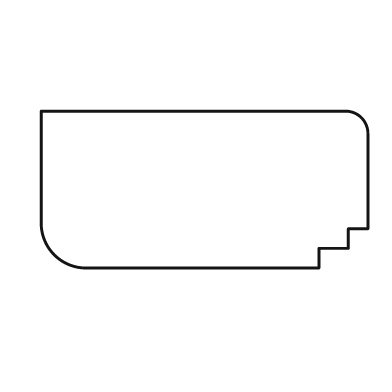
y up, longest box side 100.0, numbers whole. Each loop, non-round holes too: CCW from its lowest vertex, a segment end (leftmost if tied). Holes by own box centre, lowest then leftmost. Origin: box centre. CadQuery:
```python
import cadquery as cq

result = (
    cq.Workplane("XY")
    .moveTo(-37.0, -24.0)
    .lineTo(35.0, -24.0)
    .lineTo(35.0, -18.0)
    .lineTo(44.0, -18.0)
    .lineTo(44.0, -12.0)
    .lineTo(50.0, -12.0)
    .lineTo(50.0, 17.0)
    .threePointArc((48.0, 22.0), (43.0, 24.0))
    .lineTo(-50.0, 24.0)
    .lineTo(-50.0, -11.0)
    .threePointArc((-46.0, -20.0), (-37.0, -24.0))
    .close()
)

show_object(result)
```